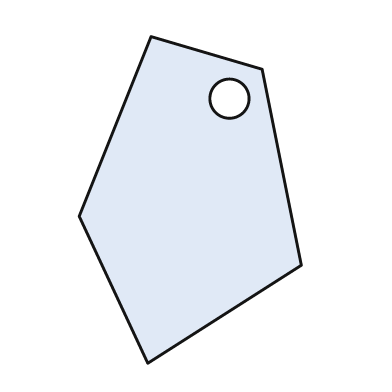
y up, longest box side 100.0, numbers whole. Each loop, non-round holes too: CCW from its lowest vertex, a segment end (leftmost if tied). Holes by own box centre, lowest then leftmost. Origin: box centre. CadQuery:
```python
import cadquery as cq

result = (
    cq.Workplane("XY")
    .moveTo(-13.0, -50.0)
    .lineTo(34.0, -20.0)
    .lineTo(22.0, 40.0)
    .lineTo(-12.0, 50.0)
    .lineTo(-34.0, -5.0)
    .close()
    .moveTo(12.0, 31.0)
    .circle(6.0)
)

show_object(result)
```